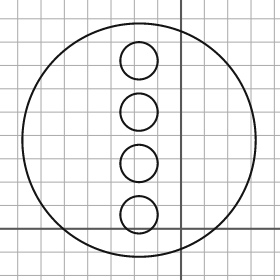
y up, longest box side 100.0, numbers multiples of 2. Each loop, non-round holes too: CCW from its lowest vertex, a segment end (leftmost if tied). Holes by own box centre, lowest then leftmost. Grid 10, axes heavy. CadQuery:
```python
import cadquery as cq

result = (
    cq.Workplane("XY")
    .moveTo(-18.0, 38.0)
    .circle(50.0)
    .moveTo(-18.0, 6.0)
    .circle(8.0)
    .moveTo(-18.0, 28.0)
    .circle(8.0)
    .moveTo(-18.0, 50.0)
    .circle(8.0)
    .moveTo(-18.0, 72.0)
    .circle(8.0)
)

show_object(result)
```